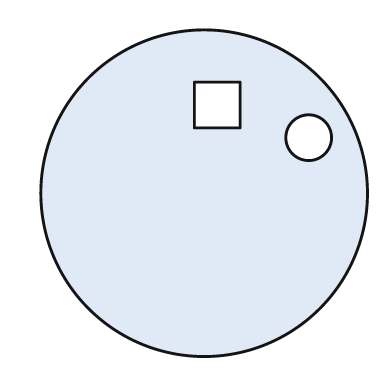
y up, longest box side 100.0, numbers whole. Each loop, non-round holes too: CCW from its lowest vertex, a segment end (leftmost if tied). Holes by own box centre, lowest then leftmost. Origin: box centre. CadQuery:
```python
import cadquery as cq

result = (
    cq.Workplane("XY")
    .moveTo(0.0, 0.0)
    .circle(50.0)
    .moveTo(32.0, 17.0)
    .circle(7.0)
    .moveTo(-3.0, 20.0)
    .lineTo(11.0, 20.0)
    .lineTo(11.0, 34.0)
    .lineTo(-3.0, 34.0)
    .close()
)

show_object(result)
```